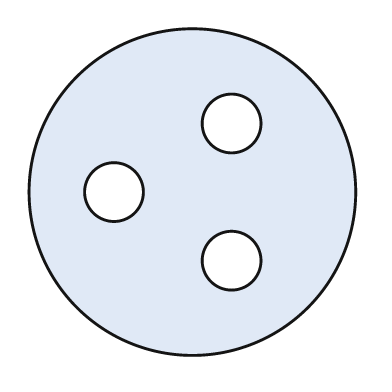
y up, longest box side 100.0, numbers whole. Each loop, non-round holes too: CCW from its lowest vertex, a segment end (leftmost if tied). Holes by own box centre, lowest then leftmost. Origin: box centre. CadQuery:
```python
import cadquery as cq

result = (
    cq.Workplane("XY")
    .moveTo(0.0, 0.0)
    .circle(50.0)
    .moveTo(12.0, -21.0)
    .circle(9.0)
    .moveTo(-24.0, 0.0)
    .circle(9.0)
    .moveTo(12.0, 21.0)
    .circle(9.0)
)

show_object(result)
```